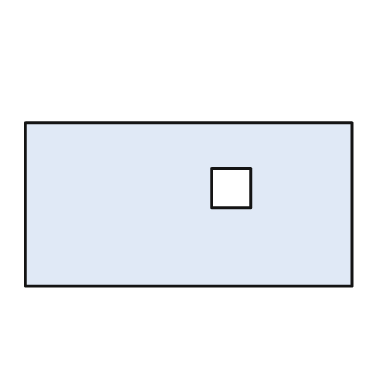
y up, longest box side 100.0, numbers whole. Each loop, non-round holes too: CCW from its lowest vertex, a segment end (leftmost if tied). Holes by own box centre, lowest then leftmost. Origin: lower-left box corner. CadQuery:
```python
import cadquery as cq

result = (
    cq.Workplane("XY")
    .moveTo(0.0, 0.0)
    .lineTo(100.0, 0.0)
    .lineTo(100.0, 50.0)
    .lineTo(0.0, 50.0)
    .close()
    .moveTo(57.0, 24.0)
    .lineTo(69.0, 24.0)
    .lineTo(69.0, 36.0)
    .lineTo(57.0, 36.0)
    .close()
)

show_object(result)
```